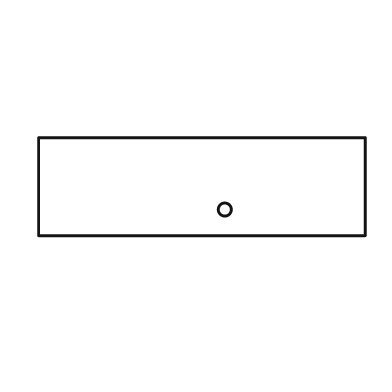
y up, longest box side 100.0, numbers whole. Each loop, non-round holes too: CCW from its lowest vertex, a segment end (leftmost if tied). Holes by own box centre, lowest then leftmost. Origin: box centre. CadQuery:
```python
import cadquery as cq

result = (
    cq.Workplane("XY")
    .moveTo(-50.0, -15.0)
    .lineTo(50.0, -15.0)
    .lineTo(50.0, 15.0)
    .lineTo(-50.0, 15.0)
    .close()
    .moveTo(7.0, -7.0)
    .circle(2.0)
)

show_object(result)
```